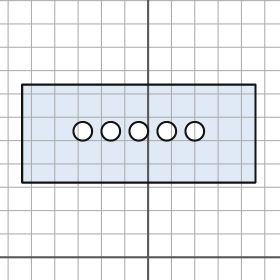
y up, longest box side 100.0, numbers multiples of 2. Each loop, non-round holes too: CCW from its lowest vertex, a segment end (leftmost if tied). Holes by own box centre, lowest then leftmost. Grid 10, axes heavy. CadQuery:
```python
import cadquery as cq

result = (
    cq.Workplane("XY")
    .moveTo(-54.0, 32.0)
    .lineTo(46.0, 32.0)
    .lineTo(46.0, 74.0)
    .lineTo(-54.0, 74.0)
    .close()
    .moveTo(-28.0, 54.0)
    .circle(4.0)
    .moveTo(-16.0, 54.0)
    .circle(4.0)
    .moveTo(-4.0, 54.0)
    .circle(4.0)
    .moveTo(8.0, 54.0)
    .circle(4.0)
    .moveTo(20.0, 54.0)
    .circle(4.0)
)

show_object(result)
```